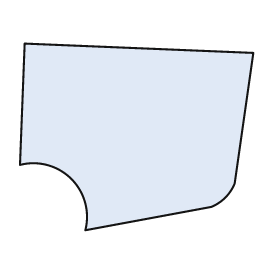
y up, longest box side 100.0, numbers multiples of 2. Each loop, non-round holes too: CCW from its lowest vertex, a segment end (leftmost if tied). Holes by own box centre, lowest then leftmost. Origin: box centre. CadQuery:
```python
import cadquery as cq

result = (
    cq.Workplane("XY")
    .moveTo(-22.0, -40.0)
    .lineTo(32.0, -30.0)
    .threePointArc((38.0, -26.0), (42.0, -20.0))
    .lineTo(50.0, 36.0)
    .lineTo(-48.0, 40.0)
    .lineTo(-50.0, -12.0)
    .threePointArc((-28.0, -18.0), (-22.0, -40.0))
    .close()
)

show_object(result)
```